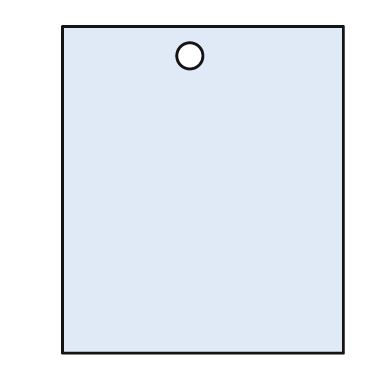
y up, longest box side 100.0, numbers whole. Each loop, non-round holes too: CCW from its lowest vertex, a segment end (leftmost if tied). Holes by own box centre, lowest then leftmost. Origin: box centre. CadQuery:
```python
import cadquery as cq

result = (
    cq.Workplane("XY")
    .moveTo(-43.0, -50.0)
    .lineTo(43.0, -50.0)
    .lineTo(43.0, 50.0)
    .lineTo(-43.0, 50.0)
    .close()
    .moveTo(-4.0, 41.0)
    .circle(4.0)
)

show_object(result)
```